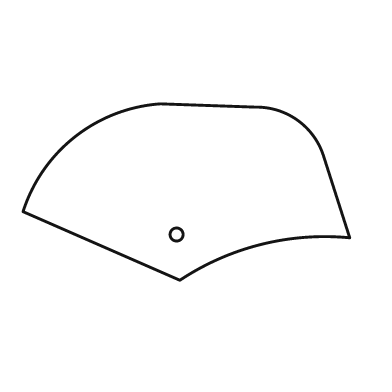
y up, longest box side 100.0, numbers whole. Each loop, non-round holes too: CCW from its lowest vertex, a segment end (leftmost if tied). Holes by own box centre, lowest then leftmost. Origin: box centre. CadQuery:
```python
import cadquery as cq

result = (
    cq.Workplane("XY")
    .moveTo(-2.0, -27.0)
    .threePointArc((23.0, -16.0), (50.0, -14.0))
    .lineTo(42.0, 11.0)
    .threePointArc((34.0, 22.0), (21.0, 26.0))
    .lineTo(-8.0, 27.0)
    .threePointArc((-34.0, 17.0), (-50.0, -6.0))
    .close()
    .moveTo(-3.0, -13.0)
    .circle(2.0)
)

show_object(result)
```